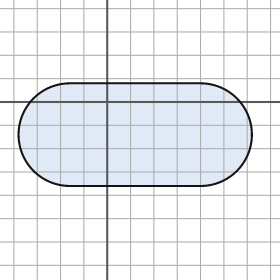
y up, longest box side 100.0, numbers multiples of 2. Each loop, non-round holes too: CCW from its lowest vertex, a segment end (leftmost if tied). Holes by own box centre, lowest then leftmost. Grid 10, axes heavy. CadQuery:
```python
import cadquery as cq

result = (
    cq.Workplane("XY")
    .moveTo(-16.0, -36.0)
    .lineTo(40.0, -36.0)
    .threePointArc((62.0, -14.0), (40.0, 8.0))
    .lineTo(-16.0, 8.0)
    .threePointArc((-38.0, -14.0), (-16.0, -36.0))
    .close()
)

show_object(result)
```